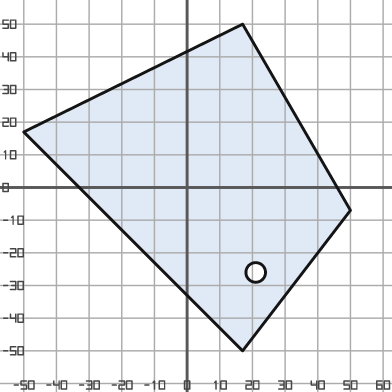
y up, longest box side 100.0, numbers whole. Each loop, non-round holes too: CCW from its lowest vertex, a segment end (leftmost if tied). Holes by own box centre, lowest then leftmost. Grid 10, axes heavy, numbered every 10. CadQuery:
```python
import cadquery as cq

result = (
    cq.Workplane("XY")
    .moveTo(17.0, -50.0)
    .lineTo(50.0, -7.0)
    .lineTo(17.0, 50.0)
    .lineTo(-50.0, 17.0)
    .close()
    .moveTo(21.0, -26.0)
    .circle(3.0)
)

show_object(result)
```